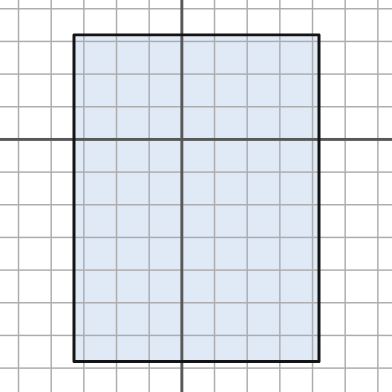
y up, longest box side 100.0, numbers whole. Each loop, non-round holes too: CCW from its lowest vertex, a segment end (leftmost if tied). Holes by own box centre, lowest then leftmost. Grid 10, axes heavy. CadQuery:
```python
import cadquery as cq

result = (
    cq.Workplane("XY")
    .moveTo(-33.0, -68.0)
    .lineTo(42.0, -68.0)
    .lineTo(42.0, 32.0)
    .lineTo(-33.0, 32.0)
    .close()
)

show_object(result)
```